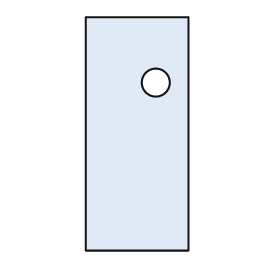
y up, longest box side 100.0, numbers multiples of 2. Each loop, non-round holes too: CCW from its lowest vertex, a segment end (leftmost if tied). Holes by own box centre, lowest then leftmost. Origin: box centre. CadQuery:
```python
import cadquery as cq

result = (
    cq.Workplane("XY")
    .moveTo(-22.0, -50.0)
    .lineTo(22.0, -50.0)
    .lineTo(22.0, 50.0)
    .lineTo(-22.0, 50.0)
    .close()
    .moveTo(8.0, 22.0)
    .circle(6.0)
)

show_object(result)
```